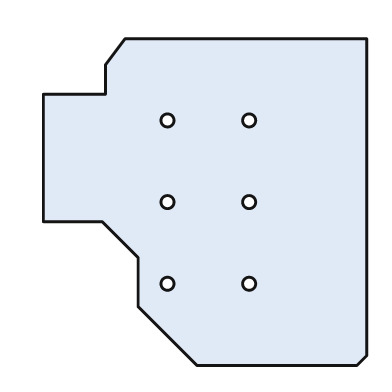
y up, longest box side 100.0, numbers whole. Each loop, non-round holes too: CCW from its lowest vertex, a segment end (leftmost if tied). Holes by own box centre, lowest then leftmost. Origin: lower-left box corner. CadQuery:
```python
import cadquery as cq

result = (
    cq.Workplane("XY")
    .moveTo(47.0, 0.0)
    .lineTo(96.0, 0.0)
    .lineTo(99.0, 3.0)
    .lineTo(99.0, 100.0)
    .lineTo(25.0, 100.0)
    .lineTo(19.0, 92.0)
    .lineTo(19.0, 83.0)
    .lineTo(0.0, 83.0)
    .lineTo(0.0, 44.0)
    .lineTo(18.0, 44.0)
    .lineTo(29.0, 33.0)
    .lineTo(29.0, 18.0)
    .close()
    .moveTo(38.0, 25.0)
    .circle(2.0)
    .moveTo(63.0, 25.0)
    .circle(2.0)
    .moveTo(38.0, 50.0)
    .circle(2.0)
    .moveTo(63.0, 50.0)
    .circle(2.0)
    .moveTo(38.0, 75.0)
    .circle(2.0)
    .moveTo(63.0, 75.0)
    .circle(2.0)
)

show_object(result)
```